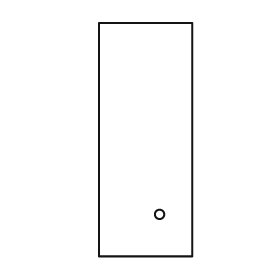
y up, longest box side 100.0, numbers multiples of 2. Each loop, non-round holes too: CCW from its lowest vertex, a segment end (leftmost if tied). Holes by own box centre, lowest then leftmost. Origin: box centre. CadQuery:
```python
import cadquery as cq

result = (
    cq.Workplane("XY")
    .moveTo(-20.0, -50.0)
    .lineTo(20.0, -50.0)
    .lineTo(20.0, 50.0)
    .lineTo(-20.0, 50.0)
    .close()
    .moveTo(6.0, -32.0)
    .circle(2.0)
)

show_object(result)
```